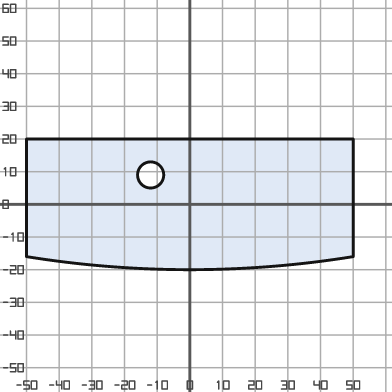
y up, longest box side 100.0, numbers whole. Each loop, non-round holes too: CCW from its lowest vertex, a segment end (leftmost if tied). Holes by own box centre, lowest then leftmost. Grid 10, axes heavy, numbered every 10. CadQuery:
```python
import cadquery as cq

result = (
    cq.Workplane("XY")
    .moveTo(-50.0, -16.0)
    .threePointArc((0.0, -20.0), (50.0, -16.0))
    .lineTo(50.0, 20.0)
    .lineTo(-50.0, 20.0)
    .close()
    .moveTo(-12.0, 9.0)
    .circle(4.0)
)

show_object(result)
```